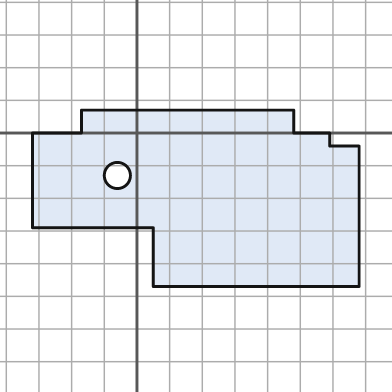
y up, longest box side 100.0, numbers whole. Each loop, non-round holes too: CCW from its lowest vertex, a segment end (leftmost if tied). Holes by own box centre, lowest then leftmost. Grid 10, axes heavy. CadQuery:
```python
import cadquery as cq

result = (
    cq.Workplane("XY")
    .moveTo(5.0, -47.0)
    .lineTo(68.0, -47.0)
    .lineTo(68.0, -4.0)
    .lineTo(59.0, -4.0)
    .lineTo(59.0, 0.0)
    .lineTo(48.0, 0.0)
    .lineTo(48.0, 7.0)
    .lineTo(-17.0, 7.0)
    .lineTo(-17.0, 0.0)
    .lineTo(-32.0, 0.0)
    .lineTo(-32.0, -29.0)
    .lineTo(5.0, -29.0)
    .close()
    .moveTo(-6.0, -13.0)
    .circle(4.0)
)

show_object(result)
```